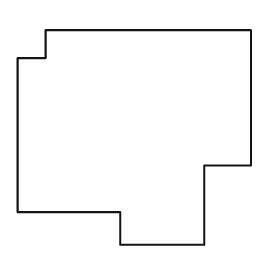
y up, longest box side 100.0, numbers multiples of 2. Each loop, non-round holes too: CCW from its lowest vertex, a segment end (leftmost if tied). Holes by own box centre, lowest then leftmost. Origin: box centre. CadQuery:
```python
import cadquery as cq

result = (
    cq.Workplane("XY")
    .moveTo(-6.0, -46.0)
    .lineTo(30.0, -46.0)
    .lineTo(30.0, -12.0)
    .lineTo(50.0, -12.0)
    .lineTo(50.0, 46.0)
    .lineTo(-38.0, 46.0)
    .lineTo(-38.0, 34.0)
    .lineTo(-50.0, 34.0)
    .lineTo(-50.0, -32.0)
    .lineTo(-6.0, -32.0)
    .close()
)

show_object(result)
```